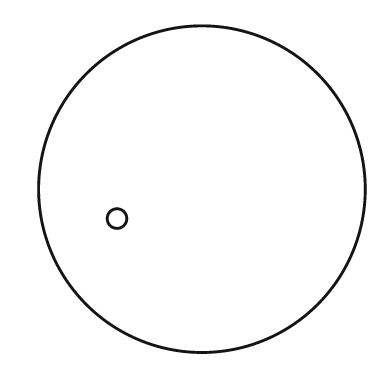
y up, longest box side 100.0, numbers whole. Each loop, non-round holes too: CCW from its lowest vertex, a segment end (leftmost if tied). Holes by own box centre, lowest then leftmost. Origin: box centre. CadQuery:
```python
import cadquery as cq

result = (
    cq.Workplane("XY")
    .moveTo(0.0, 0.0)
    .circle(50.0)
    .moveTo(-26.0, -9.0)
    .circle(3.0)
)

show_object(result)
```